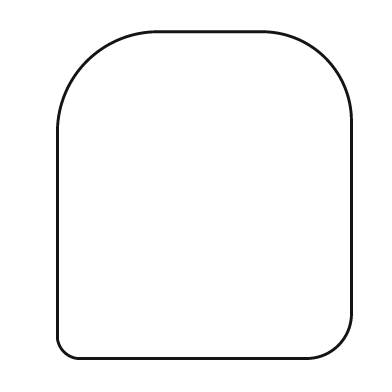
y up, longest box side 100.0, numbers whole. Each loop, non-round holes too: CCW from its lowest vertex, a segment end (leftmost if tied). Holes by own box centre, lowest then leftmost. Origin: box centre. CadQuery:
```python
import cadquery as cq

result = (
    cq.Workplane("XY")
    .moveTo(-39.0, -50.0)
    .lineTo(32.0, -50.0)
    .threePointArc((41.0, -46.0), (45.0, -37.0))
    .lineTo(45.0, 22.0)
    .threePointArc((37.0, 42.0), (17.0, 50.0))
    .lineTo(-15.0, 50.0)
    .threePointArc((-36.0, 41.0), (-45.0, 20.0))
    .lineTo(-45.0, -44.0)
    .threePointArc((-43.0, -48.0), (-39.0, -50.0))
    .close()
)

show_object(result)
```